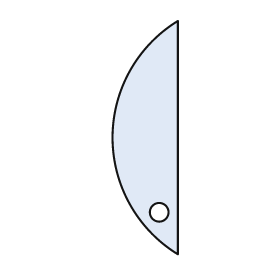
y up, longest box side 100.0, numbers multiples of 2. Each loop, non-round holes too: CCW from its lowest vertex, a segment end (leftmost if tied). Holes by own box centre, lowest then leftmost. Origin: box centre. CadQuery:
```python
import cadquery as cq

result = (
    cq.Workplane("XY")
    .moveTo(14.0, -50.0)
    .lineTo(14.0, 50.0)
    .threePointArc((-14.0, 0.0), (14.0, -50.0))
    .close()
    .moveTo(6.0, -32.0)
    .circle(4.0)
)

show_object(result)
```